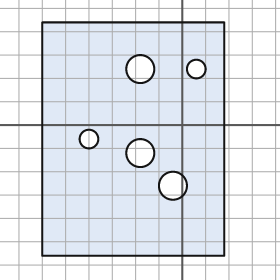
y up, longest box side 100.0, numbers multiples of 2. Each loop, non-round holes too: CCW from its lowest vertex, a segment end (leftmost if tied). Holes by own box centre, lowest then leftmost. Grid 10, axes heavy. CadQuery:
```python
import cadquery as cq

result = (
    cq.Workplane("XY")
    .moveTo(-60.0, -56.0)
    .lineTo(18.0, -56.0)
    .lineTo(18.0, 44.0)
    .lineTo(-60.0, 44.0)
    .close()
    .moveTo(-4.0, -26.0)
    .circle(6.0)
    .moveTo(-18.0, -12.0)
    .circle(6.0)
    .moveTo(-40.0, -6.0)
    .circle(4.0)
    .moveTo(-18.0, 24.0)
    .circle(6.0)
    .moveTo(6.0, 24.0)
    .circle(4.0)
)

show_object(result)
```